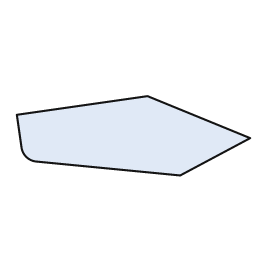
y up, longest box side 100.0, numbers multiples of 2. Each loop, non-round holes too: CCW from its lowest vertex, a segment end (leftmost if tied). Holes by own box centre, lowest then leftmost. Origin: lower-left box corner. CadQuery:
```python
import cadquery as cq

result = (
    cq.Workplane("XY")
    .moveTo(70.0, 0.0)
    .lineTo(100.0, 16.0)
    .lineTo(56.0, 34.0)
    .lineTo(0.0, 26.0)
    .lineTo(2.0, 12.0)
    .threePointArc((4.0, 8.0), (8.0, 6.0))
    .close()
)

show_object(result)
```